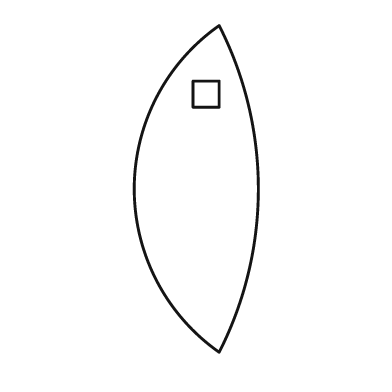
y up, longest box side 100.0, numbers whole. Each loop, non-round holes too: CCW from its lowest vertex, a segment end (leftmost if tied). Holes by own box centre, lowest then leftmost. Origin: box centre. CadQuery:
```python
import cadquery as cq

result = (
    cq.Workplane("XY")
    .moveTo(7.0, -50.0)
    .threePointArc((19.0, 0.0), (7.0, 50.0))
    .threePointArc((-19.0, 0.0), (7.0, -50.0))
    .close()
    .moveTo(-1.0, 25.0)
    .lineTo(7.0, 25.0)
    .lineTo(7.0, 33.0)
    .lineTo(-1.0, 33.0)
    .close()
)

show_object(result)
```